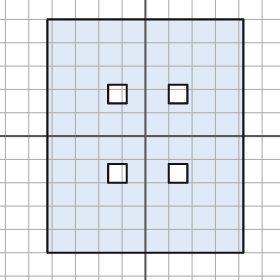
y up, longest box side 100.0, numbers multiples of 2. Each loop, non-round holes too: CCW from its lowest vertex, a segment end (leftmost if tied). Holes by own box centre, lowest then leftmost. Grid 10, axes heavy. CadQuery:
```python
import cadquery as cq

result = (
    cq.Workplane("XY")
    .moveTo(-42.0, -50.0)
    .lineTo(42.0, -50.0)
    .lineTo(42.0, 50.0)
    .lineTo(-42.0, 50.0)
    .close()
    .moveTo(-16.0, -20.0)
    .lineTo(-8.0, -20.0)
    .lineTo(-8.0, -12.0)
    .lineTo(-16.0, -12.0)
    .close()
    .moveTo(10.0, -20.0)
    .lineTo(18.0, -20.0)
    .lineTo(18.0, -12.0)
    .lineTo(10.0, -12.0)
    .close()
    .moveTo(-16.0, 14.0)
    .lineTo(-8.0, 14.0)
    .lineTo(-8.0, 22.0)
    .lineTo(-16.0, 22.0)
    .close()
    .moveTo(10.0, 14.0)
    .lineTo(18.0, 14.0)
    .lineTo(18.0, 22.0)
    .lineTo(10.0, 22.0)
    .close()
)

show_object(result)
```